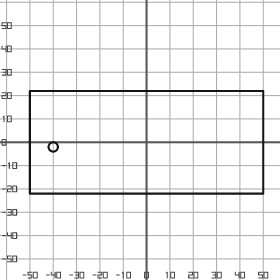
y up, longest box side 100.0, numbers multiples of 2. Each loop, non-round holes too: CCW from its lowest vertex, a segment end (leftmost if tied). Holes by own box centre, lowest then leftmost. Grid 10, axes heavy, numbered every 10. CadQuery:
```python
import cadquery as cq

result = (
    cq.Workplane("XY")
    .moveTo(-50.0, -22.0)
    .lineTo(50.0, -22.0)
    .lineTo(50.0, 22.0)
    .lineTo(-50.0, 22.0)
    .close()
    .moveTo(-40.0, -2.0)
    .circle(2.0)
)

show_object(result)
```